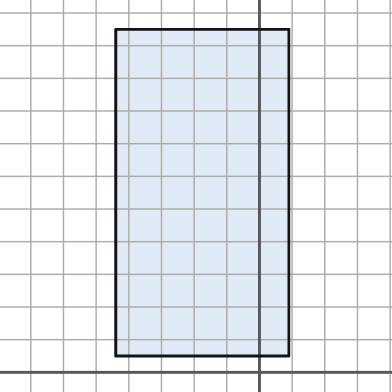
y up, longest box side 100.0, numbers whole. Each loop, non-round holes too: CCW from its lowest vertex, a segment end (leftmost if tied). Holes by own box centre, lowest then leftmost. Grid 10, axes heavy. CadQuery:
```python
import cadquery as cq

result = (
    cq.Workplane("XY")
    .moveTo(-44.0, 5.0)
    .lineTo(9.0, 5.0)
    .lineTo(9.0, 105.0)
    .lineTo(-44.0, 105.0)
    .close()
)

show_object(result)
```